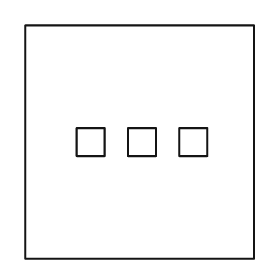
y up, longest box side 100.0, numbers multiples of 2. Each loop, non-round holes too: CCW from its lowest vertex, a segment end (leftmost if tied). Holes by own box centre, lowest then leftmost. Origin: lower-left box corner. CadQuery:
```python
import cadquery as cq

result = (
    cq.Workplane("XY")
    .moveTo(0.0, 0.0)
    .lineTo(98.0, 0.0)
    .lineTo(98.0, 100.0)
    .lineTo(0.0, 100.0)
    .close()
    .moveTo(22.0, 44.0)
    .lineTo(34.0, 44.0)
    .lineTo(34.0, 56.0)
    .lineTo(22.0, 56.0)
    .close()
    .moveTo(44.0, 44.0)
    .lineTo(56.0, 44.0)
    .lineTo(56.0, 56.0)
    .lineTo(44.0, 56.0)
    .close()
    .moveTo(66.0, 44.0)
    .lineTo(78.0, 44.0)
    .lineTo(78.0, 56.0)
    .lineTo(66.0, 56.0)
    .close()
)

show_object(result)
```